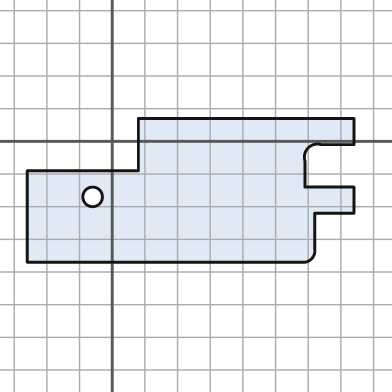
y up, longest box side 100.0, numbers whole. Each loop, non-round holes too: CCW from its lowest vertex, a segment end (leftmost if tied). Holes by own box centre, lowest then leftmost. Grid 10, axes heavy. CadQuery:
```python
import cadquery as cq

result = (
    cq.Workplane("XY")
    .moveTo(-26.0, -37.0)
    .lineTo(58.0, -37.0)
    .threePointArc((61.0, -36.0), (62.0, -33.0))
    .lineTo(62.0, -22.0)
    .lineTo(74.0, -22.0)
    .lineTo(74.0, -14.0)
    .lineTo(59.0, -14.0)
    .lineTo(59.0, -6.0)
    .threePointArc((60.0, -2.0), (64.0, -1.0))
    .lineTo(74.0, -1.0)
    .lineTo(74.0, 7.0)
    .lineTo(8.0, 7.0)
    .lineTo(8.0, -9.0)
    .lineTo(-26.0, -9.0)
    .close()
    .moveTo(-6.0, -17.0)
    .circle(3.0)
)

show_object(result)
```